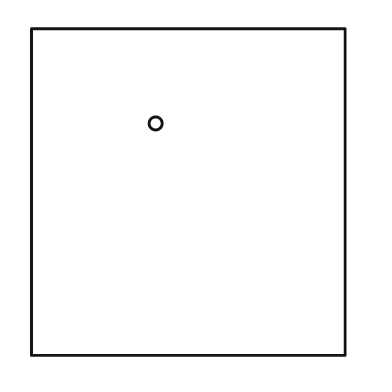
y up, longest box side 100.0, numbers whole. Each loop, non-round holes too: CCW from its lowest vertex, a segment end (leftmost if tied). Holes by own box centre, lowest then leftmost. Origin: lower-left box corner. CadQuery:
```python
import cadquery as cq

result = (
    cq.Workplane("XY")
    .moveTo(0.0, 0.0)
    .lineTo(96.0, 0.0)
    .lineTo(96.0, 100.0)
    .lineTo(0.0, 100.0)
    .close()
    .moveTo(38.0, 71.0)
    .circle(2.0)
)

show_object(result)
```